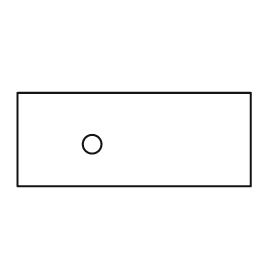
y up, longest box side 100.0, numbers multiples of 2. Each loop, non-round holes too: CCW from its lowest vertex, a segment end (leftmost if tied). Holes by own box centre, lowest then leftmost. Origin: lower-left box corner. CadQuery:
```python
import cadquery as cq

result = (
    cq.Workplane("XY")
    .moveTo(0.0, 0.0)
    .lineTo(100.0, 0.0)
    .lineTo(100.0, 40.0)
    .lineTo(0.0, 40.0)
    .close()
    .moveTo(32.0, 18.0)
    .circle(4.0)
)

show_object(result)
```